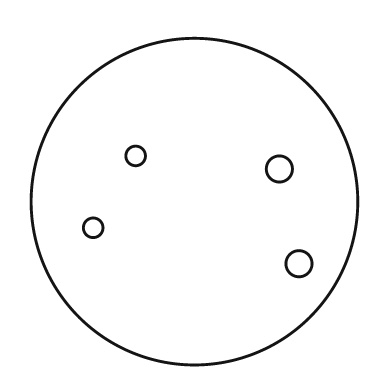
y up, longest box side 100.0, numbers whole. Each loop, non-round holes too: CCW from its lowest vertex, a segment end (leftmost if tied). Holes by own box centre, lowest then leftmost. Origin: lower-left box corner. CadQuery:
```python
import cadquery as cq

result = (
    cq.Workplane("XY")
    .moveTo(50.0, 50.0)
    .circle(50.0)
    .moveTo(82.0, 31.0)
    .circle(4.0)
    .moveTo(19.0, 42.0)
    .circle(3.0)
    .moveTo(76.0, 60.0)
    .circle(4.0)
    .moveTo(32.0, 64.0)
    .circle(3.0)
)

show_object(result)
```